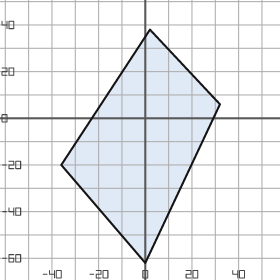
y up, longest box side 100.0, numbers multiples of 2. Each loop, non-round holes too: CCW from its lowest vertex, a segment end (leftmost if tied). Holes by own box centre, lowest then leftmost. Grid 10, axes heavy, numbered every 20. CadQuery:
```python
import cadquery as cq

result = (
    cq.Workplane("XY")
    .moveTo(0.0, -62.0)
    .lineTo(32.0, 6.0)
    .lineTo(2.0, 38.0)
    .lineTo(-36.0, -20.0)
    .close()
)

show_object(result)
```